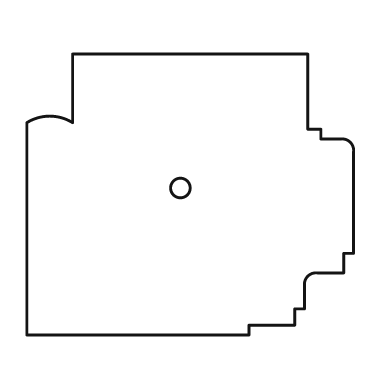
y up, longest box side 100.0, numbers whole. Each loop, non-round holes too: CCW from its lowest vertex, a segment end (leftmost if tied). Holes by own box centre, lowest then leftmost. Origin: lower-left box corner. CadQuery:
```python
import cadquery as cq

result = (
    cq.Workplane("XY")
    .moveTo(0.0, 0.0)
    .lineTo(68.0, 0.0)
    .lineTo(68.0, 3.0)
    .lineTo(82.0, 3.0)
    .lineTo(82.0, 8.0)
    .lineTo(85.0, 8.0)
    .lineTo(85.0, 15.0)
    .threePointArc((86.0, 18.0), (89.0, 19.0))
    .lineTo(97.0, 19.0)
    .lineTo(97.0, 25.0)
    .lineTo(100.0, 25.0)
    .lineTo(100.0, 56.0)
    .threePointArc((99.0, 59.0), (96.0, 60.0))
    .lineTo(90.0, 60.0)
    .lineTo(90.0, 63.0)
    .lineTo(86.0, 63.0)
    .lineTo(86.0, 86.0)
    .lineTo(14.0, 86.0)
    .lineTo(14.0, 65.0)
    .threePointArc((7.0, 67.0), (0.0, 65.0))
    .close()
    .moveTo(47.0, 45.0)
    .circle(3.0)
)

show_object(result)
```